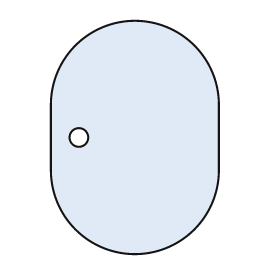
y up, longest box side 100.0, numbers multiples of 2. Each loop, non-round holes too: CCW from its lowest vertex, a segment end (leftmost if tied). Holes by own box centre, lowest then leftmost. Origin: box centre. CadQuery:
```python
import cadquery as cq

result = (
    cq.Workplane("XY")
    .moveTo(-36.0, -14.0)
    .threePointArc((0.0, -50.0), (36.0, -14.0))
    .lineTo(36.0, 14.0)
    .threePointArc((0.0, 50.0), (-36.0, 14.0))
    .close()
    .moveTo(-24.0, 0.0)
    .circle(4.0)
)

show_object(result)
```